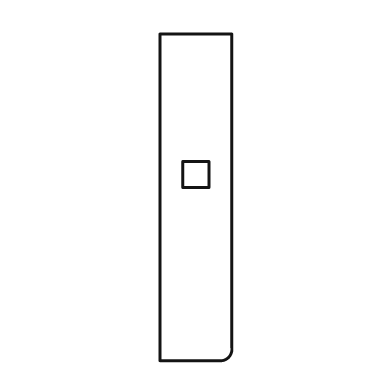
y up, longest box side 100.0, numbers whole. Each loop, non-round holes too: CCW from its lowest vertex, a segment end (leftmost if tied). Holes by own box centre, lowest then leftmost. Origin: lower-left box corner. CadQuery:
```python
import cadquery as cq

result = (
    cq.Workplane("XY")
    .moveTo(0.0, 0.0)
    .lineTo(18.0, 0.0)
    .threePointArc((21.0, 1.0), (22.0, 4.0))
    .lineTo(22.0, 100.0)
    .lineTo(0.0, 100.0)
    .close()
    .moveTo(7.0, 53.0)
    .lineTo(15.0, 53.0)
    .lineTo(15.0, 61.0)
    .lineTo(7.0, 61.0)
    .close()
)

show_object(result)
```